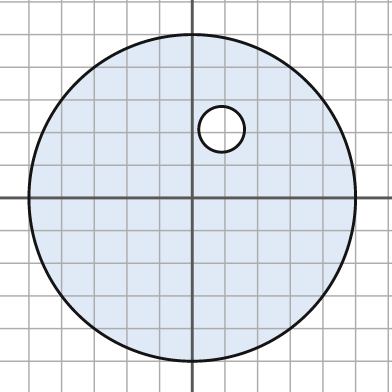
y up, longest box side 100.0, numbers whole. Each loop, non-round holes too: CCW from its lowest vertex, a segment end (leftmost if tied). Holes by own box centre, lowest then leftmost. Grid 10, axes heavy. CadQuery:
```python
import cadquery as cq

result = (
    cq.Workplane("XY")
    .moveTo(0.0, 0.0)
    .circle(50.0)
    .moveTo(9.0, 21.0)
    .circle(7.0)
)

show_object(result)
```